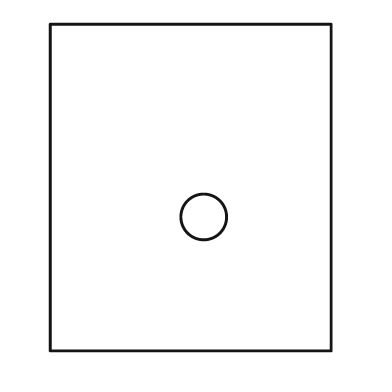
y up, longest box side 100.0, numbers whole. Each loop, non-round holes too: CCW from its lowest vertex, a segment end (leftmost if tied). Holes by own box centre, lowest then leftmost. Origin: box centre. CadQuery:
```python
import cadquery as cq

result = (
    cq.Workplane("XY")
    .moveTo(-43.0, -50.0)
    .lineTo(43.0, -50.0)
    .lineTo(43.0, 50.0)
    .lineTo(-43.0, 50.0)
    .close()
    .moveTo(4.0, -9.0)
    .circle(7.0)
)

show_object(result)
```